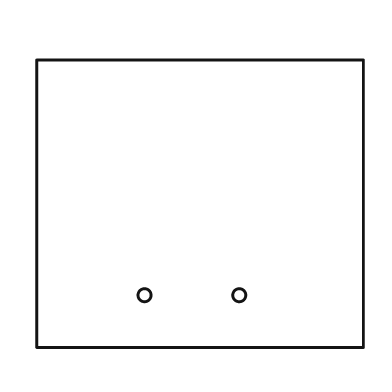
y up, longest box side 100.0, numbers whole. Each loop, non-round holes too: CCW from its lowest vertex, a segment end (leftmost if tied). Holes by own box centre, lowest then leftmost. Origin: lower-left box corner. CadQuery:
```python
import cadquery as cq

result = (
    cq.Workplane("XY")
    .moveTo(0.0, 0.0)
    .lineTo(100.0, 0.0)
    .lineTo(100.0, 88.0)
    .lineTo(0.0, 88.0)
    .close()
    .moveTo(33.0, 16.0)
    .circle(2.0)
    .moveTo(62.0, 16.0)
    .circle(2.0)
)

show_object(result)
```